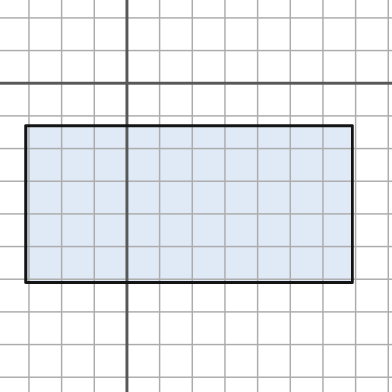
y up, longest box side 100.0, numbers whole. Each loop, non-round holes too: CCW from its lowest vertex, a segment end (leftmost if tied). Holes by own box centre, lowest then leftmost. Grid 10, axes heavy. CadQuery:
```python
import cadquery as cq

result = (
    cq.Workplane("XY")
    .moveTo(-31.0, -61.0)
    .lineTo(69.0, -61.0)
    .lineTo(69.0, -13.0)
    .lineTo(-31.0, -13.0)
    .close()
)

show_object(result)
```